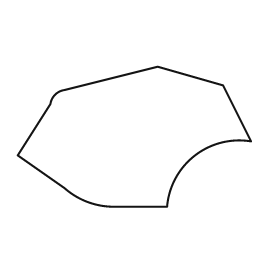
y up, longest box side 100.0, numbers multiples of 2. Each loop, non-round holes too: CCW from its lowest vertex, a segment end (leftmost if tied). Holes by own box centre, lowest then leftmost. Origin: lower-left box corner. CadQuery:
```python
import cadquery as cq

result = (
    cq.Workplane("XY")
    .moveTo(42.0, 0.0)
    .lineTo(64.0, 0.0)
    .threePointArc((76.0, 22.0), (100.0, 28.0))
    .lineTo(88.0, 52.0)
    .lineTo(60.0, 60.0)
    .lineTo(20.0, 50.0)
    .threePointArc((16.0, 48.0), (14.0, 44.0))
    .lineTo(0.0, 22.0)
    .lineTo(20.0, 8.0)
    .threePointArc((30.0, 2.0), (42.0, 0.0))
    .close()
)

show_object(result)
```